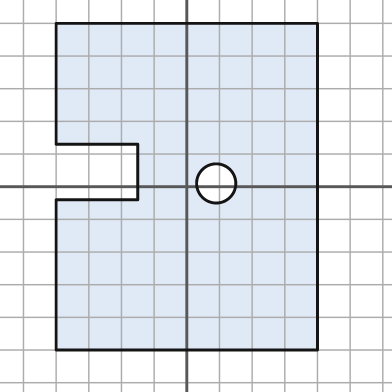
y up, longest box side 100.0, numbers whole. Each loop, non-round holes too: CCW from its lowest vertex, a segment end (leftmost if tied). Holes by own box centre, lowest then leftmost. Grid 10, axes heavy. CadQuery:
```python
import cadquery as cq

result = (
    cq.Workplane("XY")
    .moveTo(-40.0, -50.0)
    .lineTo(40.0, -50.0)
    .lineTo(40.0, 50.0)
    .lineTo(-40.0, 50.0)
    .lineTo(-40.0, 13.0)
    .lineTo(-15.0, 13.0)
    .lineTo(-15.0, -4.0)
    .lineTo(-40.0, -4.0)
    .close()
    .moveTo(9.0, 1.0)
    .circle(6.0)
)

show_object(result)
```